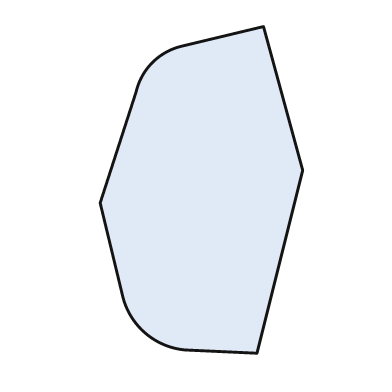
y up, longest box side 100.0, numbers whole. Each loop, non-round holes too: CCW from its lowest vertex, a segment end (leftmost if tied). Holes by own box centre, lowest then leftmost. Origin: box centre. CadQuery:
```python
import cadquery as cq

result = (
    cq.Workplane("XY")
    .moveTo(17.0, -50.0)
    .lineTo(31.0, 6.0)
    .lineTo(19.0, 50.0)
    .lineTo(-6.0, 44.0)
    .threePointArc((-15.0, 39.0), (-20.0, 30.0))
    .lineTo(-31.0, -4.0)
    .lineTo(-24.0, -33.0)
    .threePointArc((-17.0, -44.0), (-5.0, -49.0))
    .close()
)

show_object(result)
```